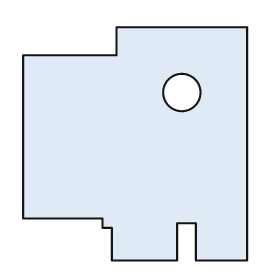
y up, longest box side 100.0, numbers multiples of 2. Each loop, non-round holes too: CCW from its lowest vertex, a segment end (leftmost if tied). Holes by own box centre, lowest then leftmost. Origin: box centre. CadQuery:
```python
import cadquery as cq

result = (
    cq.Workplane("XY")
    .moveTo(-10.0, -50.0)
    .lineTo(18.0, -50.0)
    .lineTo(18.0, -34.0)
    .lineTo(26.0, -34.0)
    .lineTo(26.0, -50.0)
    .lineTo(48.0, -50.0)
    .lineTo(48.0, 50.0)
    .lineTo(-8.0, 50.0)
    .lineTo(-8.0, 38.0)
    .lineTo(-48.0, 38.0)
    .lineTo(-48.0, -32.0)
    .lineTo(-14.0, -32.0)
    .lineTo(-14.0, -36.0)
    .lineTo(-10.0, -36.0)
    .close()
    .moveTo(20.0, 22.0)
    .circle(8.0)
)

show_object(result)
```